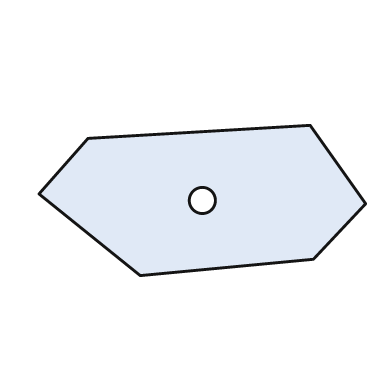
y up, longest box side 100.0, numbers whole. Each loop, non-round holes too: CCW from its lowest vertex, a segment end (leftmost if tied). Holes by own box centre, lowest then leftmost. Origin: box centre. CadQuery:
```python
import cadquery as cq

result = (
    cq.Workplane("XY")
    .moveTo(-19.0, -23.0)
    .lineTo(34.0, -18.0)
    .lineTo(50.0, -1.0)
    .lineTo(33.0, 23.0)
    .lineTo(-35.0, 19.0)
    .lineTo(-50.0, 2.0)
    .close()
    .moveTo(0.0, 0.0)
    .circle(4.0)
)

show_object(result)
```